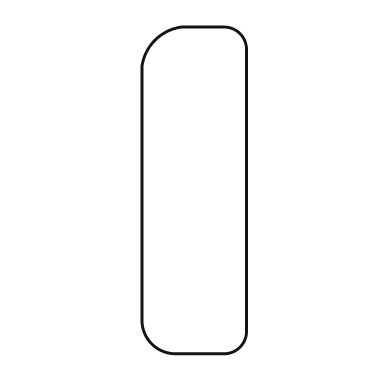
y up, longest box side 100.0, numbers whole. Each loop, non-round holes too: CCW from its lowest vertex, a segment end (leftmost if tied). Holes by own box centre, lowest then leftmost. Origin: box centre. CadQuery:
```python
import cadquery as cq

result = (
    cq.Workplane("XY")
    .moveTo(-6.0, -50.0)
    .lineTo(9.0, -50.0)
    .threePointArc((14.0, -48.0), (16.0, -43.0))
    .lineTo(16.0, 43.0)
    .threePointArc((14.0, 48.0), (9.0, 50.0))
    .lineTo(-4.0, 50.0)
    .threePointArc((-12.0, 46.0), (-16.0, 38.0))
    .lineTo(-16.0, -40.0)
    .threePointArc((-13.0, -47.0), (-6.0, -50.0))
    .close()
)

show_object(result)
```